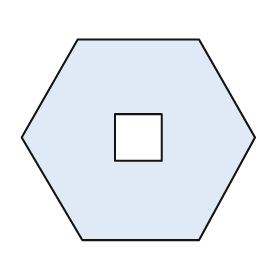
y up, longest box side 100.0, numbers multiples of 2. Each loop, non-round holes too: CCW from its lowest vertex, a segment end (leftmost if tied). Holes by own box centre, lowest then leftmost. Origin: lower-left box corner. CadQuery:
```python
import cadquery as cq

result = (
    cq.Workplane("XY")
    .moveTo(26.0, 0.0)
    .lineTo(76.0, 0.0)
    .lineTo(100.0, 44.0)
    .lineTo(76.0, 86.0)
    .lineTo(24.0, 86.0)
    .lineTo(0.0, 44.0)
    .close()
    .moveTo(40.0, 34.0)
    .lineTo(60.0, 34.0)
    .lineTo(60.0, 54.0)
    .lineTo(40.0, 54.0)
    .close()
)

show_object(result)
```